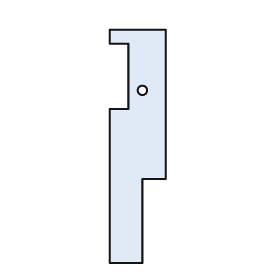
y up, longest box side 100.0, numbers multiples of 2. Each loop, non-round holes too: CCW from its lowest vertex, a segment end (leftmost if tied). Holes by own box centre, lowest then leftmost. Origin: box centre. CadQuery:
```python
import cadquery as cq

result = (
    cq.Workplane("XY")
    .moveTo(-12.0, -50.0)
    .lineTo(2.0, -50.0)
    .lineTo(2.0, -14.0)
    .lineTo(12.0, -14.0)
    .lineTo(12.0, 50.0)
    .lineTo(-12.0, 50.0)
    .lineTo(-12.0, 44.0)
    .lineTo(-4.0, 44.0)
    .lineTo(-4.0, 16.0)
    .lineTo(-12.0, 16.0)
    .close()
    .moveTo(2.0, 24.0)
    .circle(2.0)
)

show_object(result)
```